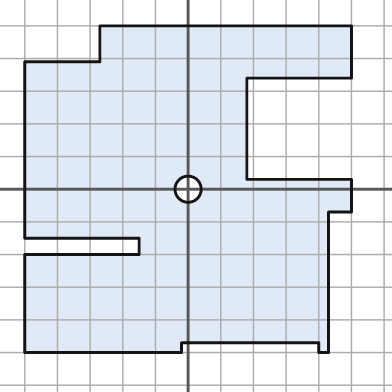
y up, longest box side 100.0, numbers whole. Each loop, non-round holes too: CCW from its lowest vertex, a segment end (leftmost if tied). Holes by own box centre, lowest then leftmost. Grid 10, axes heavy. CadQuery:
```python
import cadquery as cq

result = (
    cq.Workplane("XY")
    .moveTo(-50.0, -50.0)
    .lineTo(-2.0, -50.0)
    .lineTo(-2.0, -47.0)
    .lineTo(40.0, -47.0)
    .lineTo(40.0, -50.0)
    .lineTo(43.0, -50.0)
    .lineTo(43.0, -7.0)
    .lineTo(50.0, -7.0)
    .lineTo(50.0, 3.0)
    .lineTo(18.0, 3.0)
    .lineTo(18.0, 34.0)
    .lineTo(50.0, 34.0)
    .lineTo(50.0, 50.0)
    .lineTo(-27.0, 50.0)
    .lineTo(-27.0, 39.0)
    .lineTo(-50.0, 39.0)
    .lineTo(-50.0, -15.0)
    .lineTo(-15.0, -15.0)
    .lineTo(-15.0, -20.0)
    .lineTo(-50.0, -20.0)
    .close()
    .moveTo(0.0, 0.0)
    .circle(4.0)
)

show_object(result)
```